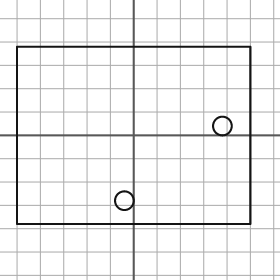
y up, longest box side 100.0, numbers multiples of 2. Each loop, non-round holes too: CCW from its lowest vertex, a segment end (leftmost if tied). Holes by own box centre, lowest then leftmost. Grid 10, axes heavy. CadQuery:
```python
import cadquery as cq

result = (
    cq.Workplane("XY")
    .moveTo(-50.0, -38.0)
    .lineTo(50.0, -38.0)
    .lineTo(50.0, 38.0)
    .lineTo(-50.0, 38.0)
    .close()
    .moveTo(-4.0, -28.0)
    .circle(4.0)
    .moveTo(38.0, 4.0)
    .circle(4.0)
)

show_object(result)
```